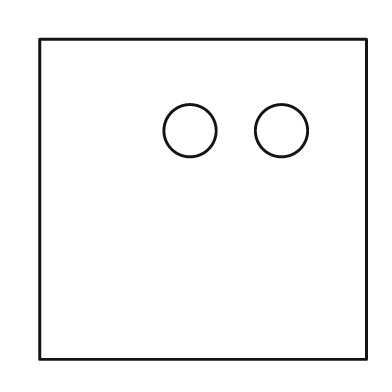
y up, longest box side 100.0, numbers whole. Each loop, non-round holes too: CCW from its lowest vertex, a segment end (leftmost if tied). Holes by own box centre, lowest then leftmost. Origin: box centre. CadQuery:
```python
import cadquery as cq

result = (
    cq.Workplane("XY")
    .moveTo(-50.0, -49.0)
    .lineTo(50.0, -49.0)
    .lineTo(50.0, 49.0)
    .lineTo(-50.0, 49.0)
    .close()
    .moveTo(-4.0, 21.0)
    .circle(8.0)
    .moveTo(24.0, 21.0)
    .circle(8.0)
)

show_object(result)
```